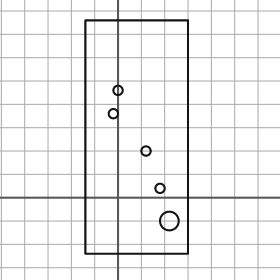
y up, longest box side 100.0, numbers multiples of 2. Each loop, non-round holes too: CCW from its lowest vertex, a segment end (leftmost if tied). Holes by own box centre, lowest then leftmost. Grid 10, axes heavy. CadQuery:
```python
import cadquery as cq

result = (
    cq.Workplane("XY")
    .moveTo(-14.0, -24.0)
    .lineTo(30.0, -24.0)
    .lineTo(30.0, 76.0)
    .lineTo(-14.0, 76.0)
    .close()
    .moveTo(22.0, -10.0)
    .circle(4.0)
    .moveTo(18.0, 4.0)
    .circle(2.0)
    .moveTo(12.0, 20.0)
    .circle(2.0)
    .moveTo(-2.0, 36.0)
    .circle(2.0)
    .moveTo(0.0, 46.0)
    .circle(2.0)
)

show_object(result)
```